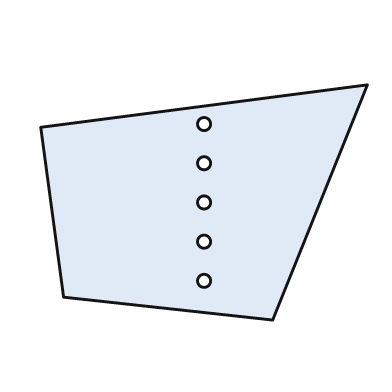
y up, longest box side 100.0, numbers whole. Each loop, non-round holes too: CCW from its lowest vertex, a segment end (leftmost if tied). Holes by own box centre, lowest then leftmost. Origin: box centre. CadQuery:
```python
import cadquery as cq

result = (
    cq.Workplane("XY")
    .moveTo(21.0, -36.0)
    .lineTo(50.0, 36.0)
    .lineTo(-50.0, 23.0)
    .lineTo(-43.0, -29.0)
    .close()
    .moveTo(0.0, -24.0)
    .circle(2.0)
    .moveTo(0.0, -12.0)
    .circle(2.0)
    .moveTo(0.0, 0.0)
    .circle(2.0)
    .moveTo(0.0, 12.0)
    .circle(2.0)
    .moveTo(0.0, 24.0)
    .circle(2.0)
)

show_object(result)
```